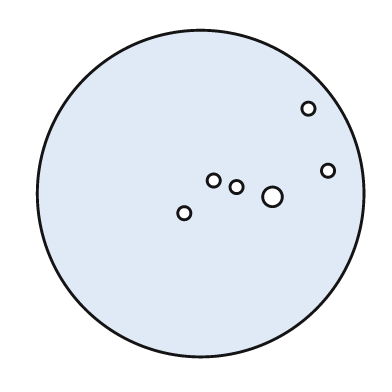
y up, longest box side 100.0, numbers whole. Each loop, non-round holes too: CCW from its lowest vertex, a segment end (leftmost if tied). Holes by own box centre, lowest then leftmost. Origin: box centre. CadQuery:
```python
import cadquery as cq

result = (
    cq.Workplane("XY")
    .moveTo(0.0, 0.0)
    .circle(50.0)
    .moveTo(-5.0, -6.0)
    .circle(2.0)
    .moveTo(22.0, -1.0)
    .circle(3.0)
    .moveTo(11.0, 2.0)
    .circle(2.0)
    .moveTo(4.0, 4.0)
    .circle(2.0)
    .moveTo(39.0, 7.0)
    .circle(2.0)
    .moveTo(33.0, 26.0)
    .circle(2.0)
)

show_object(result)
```